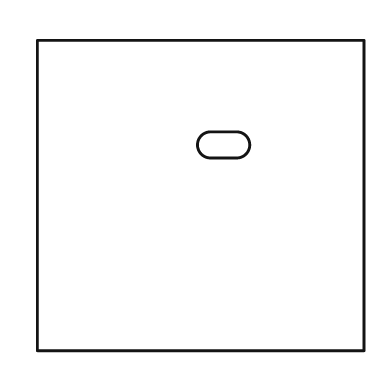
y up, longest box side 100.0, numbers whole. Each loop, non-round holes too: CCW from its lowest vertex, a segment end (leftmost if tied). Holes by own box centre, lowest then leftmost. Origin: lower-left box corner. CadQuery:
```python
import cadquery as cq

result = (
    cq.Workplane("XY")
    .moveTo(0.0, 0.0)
    .lineTo(100.0, 0.0)
    .lineTo(100.0, 95.0)
    .lineTo(0.0, 95.0)
    .close()
    .moveTo(53.0, 59.0)
    .lineTo(61.0, 59.0)
    .threePointArc((65.0, 63.0), (61.0, 67.0))
    .lineTo(53.0, 67.0)
    .threePointArc((49.0, 63.0), (53.0, 59.0))
    .close()
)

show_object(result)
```